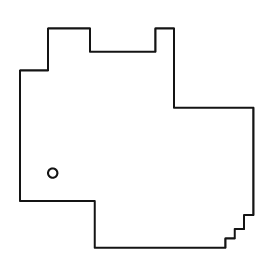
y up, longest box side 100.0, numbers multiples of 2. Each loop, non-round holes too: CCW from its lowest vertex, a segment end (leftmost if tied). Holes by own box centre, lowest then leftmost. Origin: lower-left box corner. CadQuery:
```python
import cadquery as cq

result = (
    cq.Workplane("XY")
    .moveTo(32.0, 0.0)
    .lineTo(88.0, 0.0)
    .lineTo(88.0, 4.0)
    .lineTo(92.0, 4.0)
    .lineTo(92.0, 8.0)
    .lineTo(96.0, 8.0)
    .lineTo(96.0, 14.0)
    .lineTo(100.0, 14.0)
    .lineTo(100.0, 60.0)
    .lineTo(66.0, 60.0)
    .lineTo(66.0, 94.0)
    .lineTo(58.0, 94.0)
    .lineTo(58.0, 84.0)
    .lineTo(30.0, 84.0)
    .lineTo(30.0, 94.0)
    .lineTo(12.0, 94.0)
    .lineTo(12.0, 76.0)
    .lineTo(0.0, 76.0)
    .lineTo(0.0, 20.0)
    .lineTo(32.0, 20.0)
    .close()
    .moveTo(14.0, 32.0)
    .circle(2.0)
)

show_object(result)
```